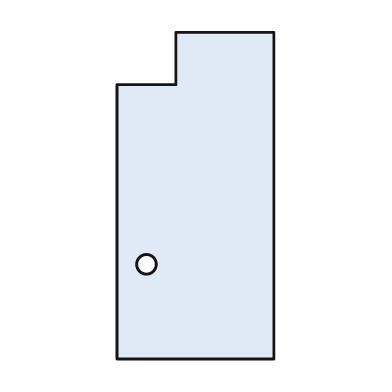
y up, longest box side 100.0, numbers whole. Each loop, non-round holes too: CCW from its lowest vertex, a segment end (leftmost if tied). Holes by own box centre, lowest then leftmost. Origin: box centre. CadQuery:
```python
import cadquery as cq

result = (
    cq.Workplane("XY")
    .moveTo(-24.0, -50.0)
    .lineTo(24.0, -50.0)
    .lineTo(24.0, 50.0)
    .lineTo(-6.0, 50.0)
    .lineTo(-6.0, 34.0)
    .lineTo(-24.0, 34.0)
    .close()
    .moveTo(-15.0, -21.0)
    .circle(3.0)
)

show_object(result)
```